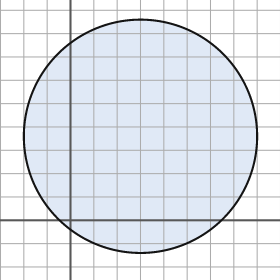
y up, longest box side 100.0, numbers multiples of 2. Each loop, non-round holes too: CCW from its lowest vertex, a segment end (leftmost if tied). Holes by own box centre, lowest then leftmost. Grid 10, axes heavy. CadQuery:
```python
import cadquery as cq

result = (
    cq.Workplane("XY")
    .moveTo(30.0, 36.0)
    .circle(50.0)
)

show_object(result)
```